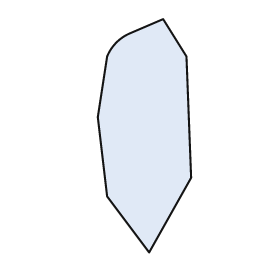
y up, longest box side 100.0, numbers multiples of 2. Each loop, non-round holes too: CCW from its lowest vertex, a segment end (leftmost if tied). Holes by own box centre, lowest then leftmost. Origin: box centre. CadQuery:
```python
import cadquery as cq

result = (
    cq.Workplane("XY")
    .moveTo(2.0, -50.0)
    .lineTo(20.0, -18.0)
    .lineTo(18.0, 34.0)
    .lineTo(8.0, 50.0)
    .lineTo(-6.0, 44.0)
    .threePointArc((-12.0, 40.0), (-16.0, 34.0))
    .lineTo(-20.0, 8.0)
    .lineTo(-16.0, -26.0)
    .close()
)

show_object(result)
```